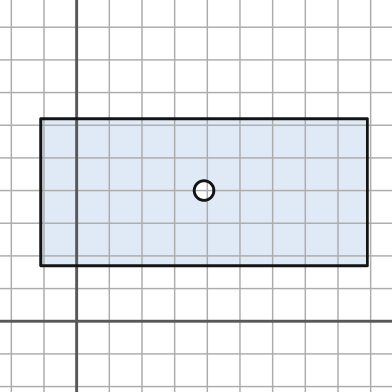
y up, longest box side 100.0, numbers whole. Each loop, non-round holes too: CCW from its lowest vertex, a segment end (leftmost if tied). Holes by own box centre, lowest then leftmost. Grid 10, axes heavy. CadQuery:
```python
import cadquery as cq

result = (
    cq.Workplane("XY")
    .moveTo(-11.0, 17.0)
    .lineTo(89.0, 17.0)
    .lineTo(89.0, 62.0)
    .lineTo(-11.0, 62.0)
    .close()
    .moveTo(39.0, 40.0)
    .circle(3.0)
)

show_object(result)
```